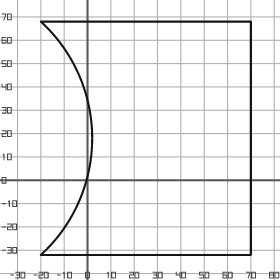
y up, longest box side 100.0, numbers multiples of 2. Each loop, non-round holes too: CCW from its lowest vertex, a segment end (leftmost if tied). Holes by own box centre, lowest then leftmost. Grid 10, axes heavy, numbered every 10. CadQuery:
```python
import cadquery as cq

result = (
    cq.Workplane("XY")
    .moveTo(-20.0, -32.0)
    .lineTo(70.0, -32.0)
    .lineTo(70.0, 68.0)
    .lineTo(-20.0, 68.0)
    .threePointArc((2.0, 18.0), (-20.0, -32.0))
    .close()
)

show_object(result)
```